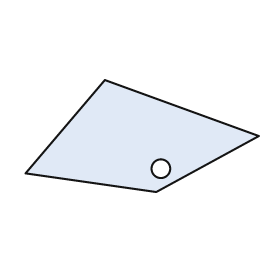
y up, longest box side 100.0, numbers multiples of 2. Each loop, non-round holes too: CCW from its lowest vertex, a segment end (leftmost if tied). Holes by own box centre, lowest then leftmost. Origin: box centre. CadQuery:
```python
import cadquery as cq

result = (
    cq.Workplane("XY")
    .moveTo(6.0, -24.0)
    .lineTo(50.0, 0.0)
    .lineTo(-16.0, 24.0)
    .lineTo(-50.0, -16.0)
    .close()
    .moveTo(8.0, -14.0)
    .circle(4.0)
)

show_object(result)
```